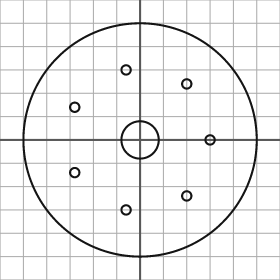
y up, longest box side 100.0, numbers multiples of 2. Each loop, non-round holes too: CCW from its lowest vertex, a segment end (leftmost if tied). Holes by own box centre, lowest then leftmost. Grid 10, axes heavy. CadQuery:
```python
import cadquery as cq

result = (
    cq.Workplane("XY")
    .moveTo(0.0, 0.0)
    .circle(50.0)
    .moveTo(-6.0, -30.0)
    .circle(2.0)
    .moveTo(20.0, -24.0)
    .circle(2.0)
    .moveTo(-28.0, -14.0)
    .circle(2.0)
    .moveTo(0.0, 0.0)
    .circle(8.0)
    .moveTo(30.0, 0.0)
    .circle(2.0)
    .moveTo(-28.0, 14.0)
    .circle(2.0)
    .moveTo(20.0, 24.0)
    .circle(2.0)
    .moveTo(-6.0, 30.0)
    .circle(2.0)
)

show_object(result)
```